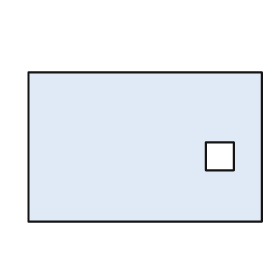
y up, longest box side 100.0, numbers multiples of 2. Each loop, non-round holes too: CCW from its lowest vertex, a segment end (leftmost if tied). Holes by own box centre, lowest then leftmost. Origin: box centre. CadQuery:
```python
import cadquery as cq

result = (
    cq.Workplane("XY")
    .moveTo(-50.0, -32.0)
    .lineTo(50.0, -32.0)
    .lineTo(50.0, 32.0)
    .lineTo(-50.0, 32.0)
    .close()
    .moveTo(26.0, -10.0)
    .lineTo(38.0, -10.0)
    .lineTo(38.0, 2.0)
    .lineTo(26.0, 2.0)
    .close()
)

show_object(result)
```